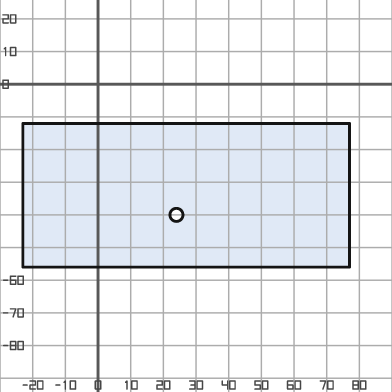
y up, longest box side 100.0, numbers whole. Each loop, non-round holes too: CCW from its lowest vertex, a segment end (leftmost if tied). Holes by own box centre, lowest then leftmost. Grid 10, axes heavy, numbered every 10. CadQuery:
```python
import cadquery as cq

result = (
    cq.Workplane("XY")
    .moveTo(-23.0, -56.0)
    .lineTo(77.0, -56.0)
    .lineTo(77.0, -12.0)
    .lineTo(-23.0, -12.0)
    .close()
    .moveTo(24.0, -40.0)
    .circle(2.0)
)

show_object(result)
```